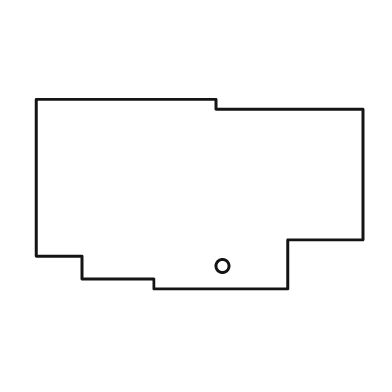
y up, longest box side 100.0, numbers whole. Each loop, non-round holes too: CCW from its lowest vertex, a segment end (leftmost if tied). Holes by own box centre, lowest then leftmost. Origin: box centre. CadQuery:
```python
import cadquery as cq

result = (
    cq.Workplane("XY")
    .moveTo(-14.0, -29.0)
    .lineTo(27.0, -29.0)
    .lineTo(27.0, -14.0)
    .lineTo(50.0, -14.0)
    .lineTo(50.0, 26.0)
    .lineTo(5.0, 26.0)
    .lineTo(5.0, 29.0)
    .lineTo(-50.0, 29.0)
    .lineTo(-50.0, -19.0)
    .lineTo(-36.0, -19.0)
    .lineTo(-36.0, -26.0)
    .lineTo(-14.0, -26.0)
    .close()
    .moveTo(7.0, -22.0)
    .circle(2.0)
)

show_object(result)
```